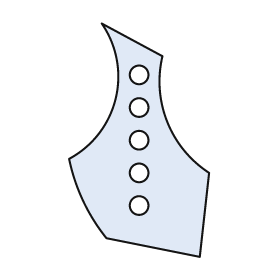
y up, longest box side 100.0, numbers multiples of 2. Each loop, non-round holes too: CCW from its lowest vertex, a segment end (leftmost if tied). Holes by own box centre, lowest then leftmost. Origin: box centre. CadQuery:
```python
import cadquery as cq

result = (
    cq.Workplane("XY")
    .moveTo(26.0, -50.0)
    .lineTo(30.0, -14.0)
    .threePointArc((12.0, 8.0), (10.0, 36.0))
    .lineTo(-16.0, 50.0)
    .threePointArc((-10.0, 18.0), (-30.0, -8.0))
    .threePointArc((-24.0, -26.0), (-14.0, -42.0))
    .close()
    .moveTo(0.0, -28.0)
    .circle(4.0)
    .moveTo(0.0, -14.0)
    .circle(4.0)
    .moveTo(0.0, 0.0)
    .circle(4.0)
    .moveTo(0.0, 14.0)
    .circle(4.0)
    .moveTo(0.0, 28.0)
    .circle(4.0)
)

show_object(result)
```